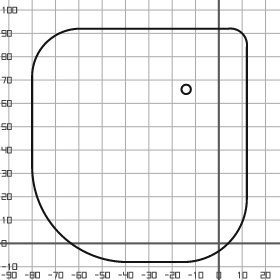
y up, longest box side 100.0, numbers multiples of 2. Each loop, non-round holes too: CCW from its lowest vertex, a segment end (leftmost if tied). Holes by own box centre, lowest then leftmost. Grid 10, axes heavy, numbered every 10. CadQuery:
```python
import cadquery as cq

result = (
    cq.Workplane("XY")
    .moveTo(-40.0, -8.0)
    .lineTo(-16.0, -8.0)
    .threePointArc((4.0, 0.0), (12.0, 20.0))
    .lineTo(12.0, 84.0)
    .threePointArc((10.0, 90.0), (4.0, 92.0))
    .lineTo(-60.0, 92.0)
    .threePointArc((-74.0, 86.0), (-80.0, 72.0))
    .lineTo(-80.0, 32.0)
    .threePointArc((-68.0, 4.0), (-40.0, -8.0))
    .close()
    .moveTo(-14.0, 66.0)
    .circle(2.0)
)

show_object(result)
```